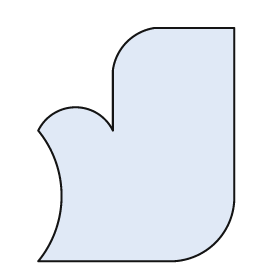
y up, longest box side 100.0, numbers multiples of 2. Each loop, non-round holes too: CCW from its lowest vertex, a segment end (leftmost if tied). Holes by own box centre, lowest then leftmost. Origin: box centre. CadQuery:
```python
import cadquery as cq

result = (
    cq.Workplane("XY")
    .moveTo(-42.0, -50.0)
    .lineTo(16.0, -50.0)
    .threePointArc((34.0, -42.0), (42.0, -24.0))
    .lineTo(42.0, 50.0)
    .lineTo(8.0, 50.0)
    .threePointArc((-4.0, 44.0), (-10.0, 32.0))
    .lineTo(-10.0, 6.0)
    .threePointArc((-26.0, 16.0), (-42.0, 6.0))
    .threePointArc((-32.0, -22.0), (-42.0, -50.0))
    .close()
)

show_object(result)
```